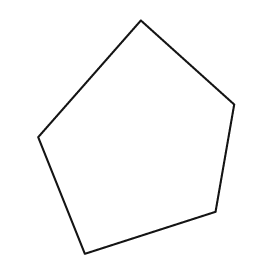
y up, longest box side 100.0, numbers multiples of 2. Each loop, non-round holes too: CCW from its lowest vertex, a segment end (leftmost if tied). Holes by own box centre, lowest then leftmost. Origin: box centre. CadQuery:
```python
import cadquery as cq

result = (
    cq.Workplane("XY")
    .moveTo(-22.0, -50.0)
    .lineTo(34.0, -32.0)
    .lineTo(42.0, 14.0)
    .lineTo(2.0, 50.0)
    .lineTo(-42.0, 0.0)
    .close()
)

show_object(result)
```